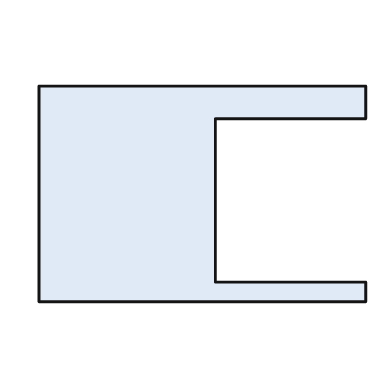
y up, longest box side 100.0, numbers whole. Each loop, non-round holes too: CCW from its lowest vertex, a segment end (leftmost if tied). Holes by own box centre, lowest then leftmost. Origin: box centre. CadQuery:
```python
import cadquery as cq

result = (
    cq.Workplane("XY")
    .moveTo(-50.0, -33.0)
    .lineTo(50.0, -33.0)
    .lineTo(50.0, -27.0)
    .lineTo(4.0, -27.0)
    .lineTo(4.0, 23.0)
    .lineTo(50.0, 23.0)
    .lineTo(50.0, 33.0)
    .lineTo(-50.0, 33.0)
    .close()
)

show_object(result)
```